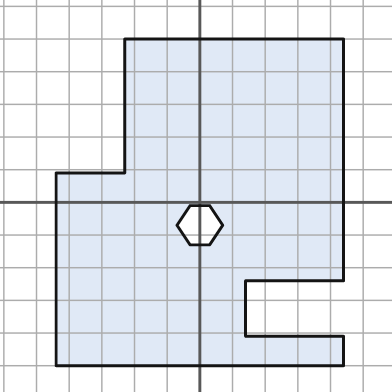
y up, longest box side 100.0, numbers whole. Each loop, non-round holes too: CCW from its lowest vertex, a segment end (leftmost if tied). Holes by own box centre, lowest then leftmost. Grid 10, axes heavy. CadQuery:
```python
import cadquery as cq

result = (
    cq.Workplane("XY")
    .moveTo(-44.0, -50.0)
    .lineTo(44.0, -50.0)
    .lineTo(44.0, -41.0)
    .lineTo(14.0, -41.0)
    .lineTo(14.0, -24.0)
    .lineTo(44.0, -24.0)
    .lineTo(44.0, 50.0)
    .lineTo(-23.0, 50.0)
    .lineTo(-23.0, 9.0)
    .lineTo(-44.0, 9.0)
    .close()
    .moveTo(-3.0, -13.0)
    .lineTo(3.0, -13.0)
    .lineTo(7.0, -7.0)
    .lineTo(3.0, -1.0)
    .lineTo(-3.0, -1.0)
    .lineTo(-7.0, -7.0)
    .close()
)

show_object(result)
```